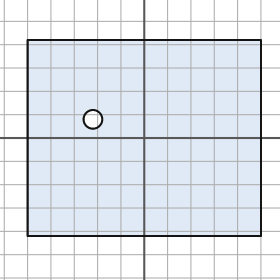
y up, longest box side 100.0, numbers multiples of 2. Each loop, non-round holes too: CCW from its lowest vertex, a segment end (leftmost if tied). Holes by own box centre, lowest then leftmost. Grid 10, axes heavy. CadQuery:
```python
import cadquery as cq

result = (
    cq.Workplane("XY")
    .moveTo(-50.0, -42.0)
    .lineTo(50.0, -42.0)
    .lineTo(50.0, 42.0)
    .lineTo(-50.0, 42.0)
    .close()
    .moveTo(-22.0, 8.0)
    .circle(4.0)
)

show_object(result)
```